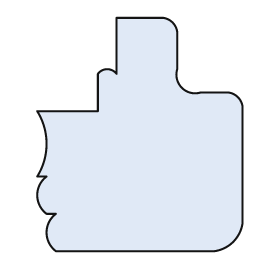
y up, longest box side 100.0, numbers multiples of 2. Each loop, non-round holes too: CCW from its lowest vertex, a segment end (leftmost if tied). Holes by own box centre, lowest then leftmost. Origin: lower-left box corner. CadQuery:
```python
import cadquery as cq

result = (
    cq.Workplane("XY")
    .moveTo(8.0, 0.0)
    .lineTo(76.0, 0.0)
    .threePointArc((84.0, 4.0), (88.0, 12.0))
    .lineTo(88.0, 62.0)
    .threePointArc((86.0, 66.0), (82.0, 68.0))
    .lineTo(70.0, 68.0)
    .threePointArc((62.0, 70.0), (60.0, 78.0))
    .lineTo(60.0, 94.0)
    .threePointArc((58.0, 98.0), (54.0, 100.0))
    .lineTo(34.0, 100.0)
    .lineTo(34.0, 76.0)
    .threePointArc((30.0, 78.0), (26.0, 76.0))
    .lineTo(26.0, 60.0)
    .lineTo(0.0, 60.0)
    .threePointArc((4.0, 46.0), (0.0, 32.0))
    .lineTo(4.0, 32.0)
    .threePointArc((0.0, 24.0), (4.0, 16.0))
    .lineTo(8.0, 16.0)
    .threePointArc((4.0, 8.0), (8.0, 0.0))
    .close()
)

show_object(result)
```